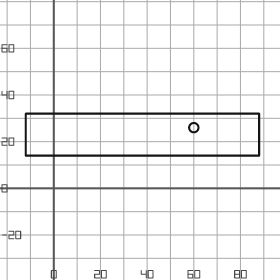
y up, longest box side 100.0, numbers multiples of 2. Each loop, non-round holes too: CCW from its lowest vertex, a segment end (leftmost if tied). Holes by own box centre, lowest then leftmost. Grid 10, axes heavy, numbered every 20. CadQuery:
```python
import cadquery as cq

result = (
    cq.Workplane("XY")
    .moveTo(-12.0, 14.0)
    .lineTo(88.0, 14.0)
    .lineTo(88.0, 32.0)
    .lineTo(-12.0, 32.0)
    .close()
    .moveTo(60.0, 26.0)
    .circle(2.0)
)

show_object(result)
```